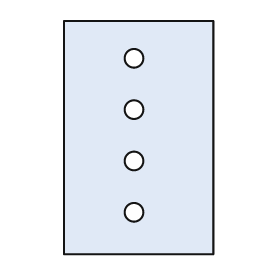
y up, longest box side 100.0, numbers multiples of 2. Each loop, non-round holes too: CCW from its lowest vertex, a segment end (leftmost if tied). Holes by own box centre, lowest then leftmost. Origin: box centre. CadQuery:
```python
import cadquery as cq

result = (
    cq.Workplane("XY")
    .moveTo(-32.0, -50.0)
    .lineTo(32.0, -50.0)
    .lineTo(32.0, 50.0)
    .lineTo(-32.0, 50.0)
    .close()
    .moveTo(-2.0, -32.0)
    .circle(4.0)
    .moveTo(-2.0, -10.0)
    .circle(4.0)
    .moveTo(-2.0, 12.0)
    .circle(4.0)
    .moveTo(-2.0, 34.0)
    .circle(4.0)
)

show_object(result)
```